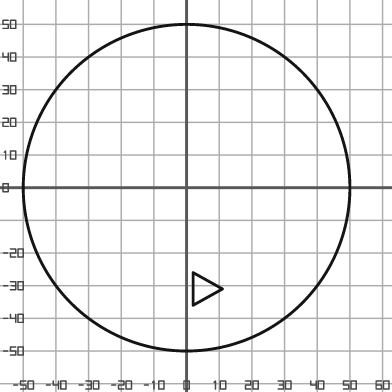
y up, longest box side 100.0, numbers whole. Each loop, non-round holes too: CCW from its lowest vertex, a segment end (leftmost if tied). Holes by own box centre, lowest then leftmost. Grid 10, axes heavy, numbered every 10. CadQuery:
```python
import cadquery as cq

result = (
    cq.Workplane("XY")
    .moveTo(0.0, 0.0)
    .circle(50.0)
    .moveTo(2.0, -36.0)
    .lineTo(11.0, -31.0)
    .lineTo(2.0, -26.0)
    .close()
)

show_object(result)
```